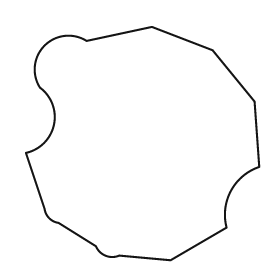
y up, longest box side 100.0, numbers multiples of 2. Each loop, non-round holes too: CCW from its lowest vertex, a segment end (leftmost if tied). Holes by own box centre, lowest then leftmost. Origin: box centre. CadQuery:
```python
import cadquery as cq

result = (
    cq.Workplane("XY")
    .moveTo(12.0, -50.0)
    .lineTo(36.0, -36.0)
    .threePointArc((38.0, -20.0), (50.0, -10.0))
    .lineTo(48.0, 18.0)
    .lineTo(30.0, 40.0)
    .lineTo(4.0, 50.0)
    .lineTo(-24.0, 44.0)
    .threePointArc((-42.0, 42.0), (-44.0, 24.0))
    .threePointArc((-38.0, 8.0), (-50.0, -4.0))
    .lineTo(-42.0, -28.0)
    .threePointArc((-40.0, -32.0), (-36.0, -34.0))
    .lineTo(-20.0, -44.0)
    .threePointArc((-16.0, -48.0), (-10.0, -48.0))
    .close()
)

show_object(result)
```